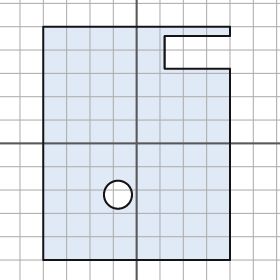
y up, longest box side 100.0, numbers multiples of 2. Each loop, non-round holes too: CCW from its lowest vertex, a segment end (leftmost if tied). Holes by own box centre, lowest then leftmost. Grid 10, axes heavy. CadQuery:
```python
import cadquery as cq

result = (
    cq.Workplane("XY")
    .moveTo(-40.0, -50.0)
    .lineTo(40.0, -50.0)
    .lineTo(40.0, 32.0)
    .lineTo(12.0, 32.0)
    .lineTo(12.0, 46.0)
    .lineTo(40.0, 46.0)
    .lineTo(40.0, 50.0)
    .lineTo(-40.0, 50.0)
    .close()
    .moveTo(-8.0, -22.0)
    .circle(6.0)
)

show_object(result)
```